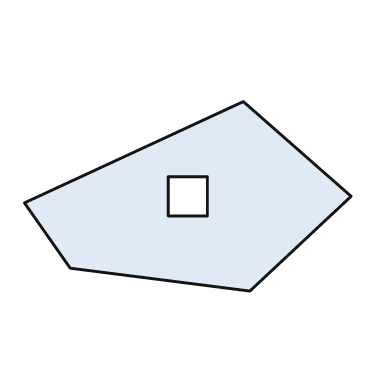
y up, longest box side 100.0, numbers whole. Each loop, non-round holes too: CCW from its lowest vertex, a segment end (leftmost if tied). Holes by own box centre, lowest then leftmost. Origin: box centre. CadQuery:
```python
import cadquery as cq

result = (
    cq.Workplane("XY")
    .moveTo(19.0, -29.0)
    .lineTo(50.0, 0.0)
    .lineTo(17.0, 29.0)
    .lineTo(-50.0, -2.0)
    .lineTo(-36.0, -22.0)
    .close()
    .moveTo(-6.0, -6.0)
    .lineTo(6.0, -6.0)
    .lineTo(6.0, 6.0)
    .lineTo(-6.0, 6.0)
    .close()
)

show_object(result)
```